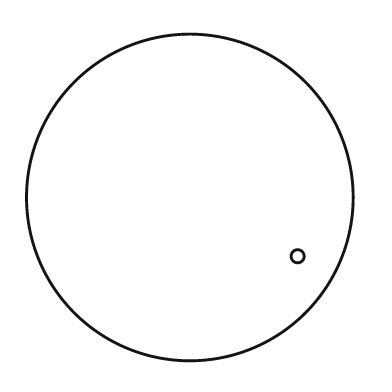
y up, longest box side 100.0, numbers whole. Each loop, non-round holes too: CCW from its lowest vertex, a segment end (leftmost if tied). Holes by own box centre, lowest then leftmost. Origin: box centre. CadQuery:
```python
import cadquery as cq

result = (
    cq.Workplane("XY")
    .moveTo(0.0, 0.0)
    .circle(50.0)
    .moveTo(33.0, -18.0)
    .circle(2.0)
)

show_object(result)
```